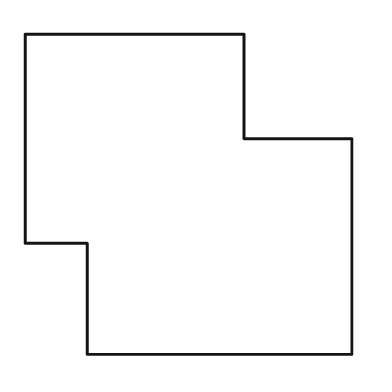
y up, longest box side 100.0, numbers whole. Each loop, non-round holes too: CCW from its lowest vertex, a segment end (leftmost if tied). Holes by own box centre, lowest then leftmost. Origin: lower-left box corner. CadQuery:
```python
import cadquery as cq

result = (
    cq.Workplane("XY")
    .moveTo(19.0, 0.0)
    .lineTo(100.0, 0.0)
    .lineTo(100.0, 66.0)
    .lineTo(67.0, 66.0)
    .lineTo(67.0, 98.0)
    .lineTo(0.0, 98.0)
    .lineTo(0.0, 34.0)
    .lineTo(19.0, 34.0)
    .close()
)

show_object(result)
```